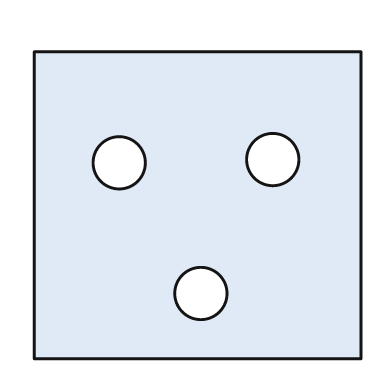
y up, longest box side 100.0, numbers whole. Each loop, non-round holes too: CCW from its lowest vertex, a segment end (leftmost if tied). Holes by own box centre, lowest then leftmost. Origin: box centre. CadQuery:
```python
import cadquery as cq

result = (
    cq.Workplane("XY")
    .moveTo(-50.0, -47.0)
    .lineTo(50.0, -47.0)
    .lineTo(50.0, 47.0)
    .lineTo(-50.0, 47.0)
    .close()
    .moveTo(1.0, -27.0)
    .circle(8.0)
    .moveTo(-24.0, 13.0)
    .circle(8.0)
    .moveTo(23.0, 14.0)
    .circle(8.0)
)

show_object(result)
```